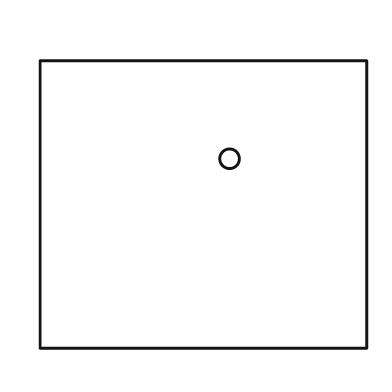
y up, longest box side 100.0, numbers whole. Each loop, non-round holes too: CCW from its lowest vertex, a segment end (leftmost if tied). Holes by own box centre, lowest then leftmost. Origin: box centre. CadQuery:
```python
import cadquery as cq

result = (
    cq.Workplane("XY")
    .moveTo(-50.0, -44.0)
    .lineTo(50.0, -44.0)
    .lineTo(50.0, 44.0)
    .lineTo(-50.0, 44.0)
    .close()
    .moveTo(8.0, 14.0)
    .circle(3.0)
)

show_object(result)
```